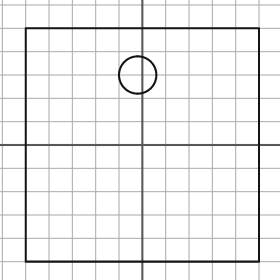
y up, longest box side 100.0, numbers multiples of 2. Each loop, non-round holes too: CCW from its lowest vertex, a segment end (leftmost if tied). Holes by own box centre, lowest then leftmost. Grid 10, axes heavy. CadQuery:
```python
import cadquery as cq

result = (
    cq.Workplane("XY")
    .moveTo(-50.0, -50.0)
    .lineTo(50.0, -50.0)
    .lineTo(50.0, 50.0)
    .lineTo(-50.0, 50.0)
    .close()
    .moveTo(-2.0, 30.0)
    .circle(8.0)
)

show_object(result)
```